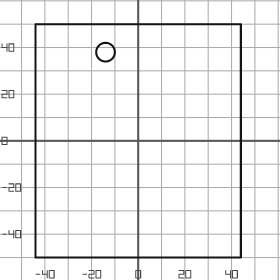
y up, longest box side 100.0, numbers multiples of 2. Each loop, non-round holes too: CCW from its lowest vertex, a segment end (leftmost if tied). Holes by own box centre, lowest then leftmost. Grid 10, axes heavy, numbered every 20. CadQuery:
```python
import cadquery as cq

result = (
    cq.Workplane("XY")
    .moveTo(-44.0, -50.0)
    .lineTo(44.0, -50.0)
    .lineTo(44.0, 50.0)
    .lineTo(-44.0, 50.0)
    .close()
    .moveTo(-14.0, 38.0)
    .circle(4.0)
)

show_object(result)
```